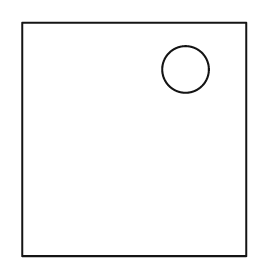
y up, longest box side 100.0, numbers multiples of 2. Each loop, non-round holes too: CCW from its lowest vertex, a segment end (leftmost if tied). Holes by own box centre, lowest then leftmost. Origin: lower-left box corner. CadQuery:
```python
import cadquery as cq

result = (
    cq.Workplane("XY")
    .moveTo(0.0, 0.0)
    .lineTo(96.0, 0.0)
    .lineTo(96.0, 100.0)
    .lineTo(0.0, 100.0)
    .close()
    .moveTo(70.0, 80.0)
    .circle(10.0)
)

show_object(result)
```